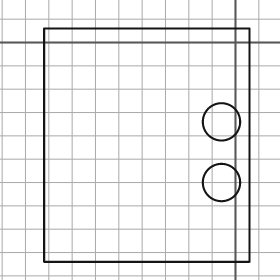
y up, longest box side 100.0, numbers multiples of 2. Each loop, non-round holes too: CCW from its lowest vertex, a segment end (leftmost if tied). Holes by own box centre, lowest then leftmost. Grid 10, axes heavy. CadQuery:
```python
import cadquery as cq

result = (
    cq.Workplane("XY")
    .moveTo(-82.0, -94.0)
    .lineTo(6.0, -94.0)
    .lineTo(6.0, 6.0)
    .lineTo(-82.0, 6.0)
    .close()
    .moveTo(-6.0, -60.0)
    .circle(8.0)
    .moveTo(-6.0, -34.0)
    .circle(8.0)
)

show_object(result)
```